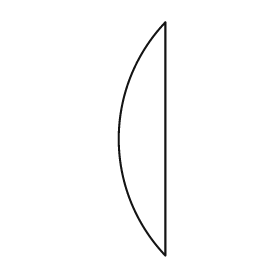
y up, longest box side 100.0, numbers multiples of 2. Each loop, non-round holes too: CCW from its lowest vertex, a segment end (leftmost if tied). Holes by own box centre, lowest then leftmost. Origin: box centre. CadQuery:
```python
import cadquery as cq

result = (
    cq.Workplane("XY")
    .moveTo(10.0, -50.0)
    .lineTo(10.0, 50.0)
    .threePointArc((-10.0, 0.0), (10.0, -50.0))
    .close()
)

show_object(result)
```